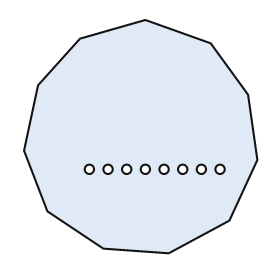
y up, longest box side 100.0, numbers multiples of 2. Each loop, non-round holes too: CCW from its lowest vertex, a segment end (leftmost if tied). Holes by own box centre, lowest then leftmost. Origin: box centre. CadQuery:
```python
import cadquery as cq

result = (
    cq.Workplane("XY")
    .moveTo(12.0, -50.0)
    .lineTo(38.0, -36.0)
    .lineTo(50.0, -10.0)
    .lineTo(46.0, 18.0)
    .lineTo(30.0, 40.0)
    .lineTo(2.0, 50.0)
    .lineTo(-26.0, 42.0)
    .lineTo(-44.0, 22.0)
    .lineTo(-50.0, -6.0)
    .lineTo(-40.0, -32.0)
    .lineTo(-16.0, -48.0)
    .close()
    .moveTo(-22.0, -14.0)
    .circle(2.0)
    .moveTo(-14.0, -14.0)
    .circle(2.0)
    .moveTo(-6.0, -14.0)
    .circle(2.0)
    .moveTo(2.0, -14.0)
    .circle(2.0)
    .moveTo(10.0, -14.0)
    .circle(2.0)
    .moveTo(18.0, -14.0)
    .circle(2.0)
    .moveTo(26.0, -14.0)
    .circle(2.0)
    .moveTo(34.0, -14.0)
    .circle(2.0)
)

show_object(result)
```